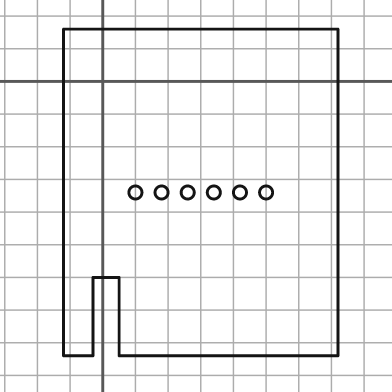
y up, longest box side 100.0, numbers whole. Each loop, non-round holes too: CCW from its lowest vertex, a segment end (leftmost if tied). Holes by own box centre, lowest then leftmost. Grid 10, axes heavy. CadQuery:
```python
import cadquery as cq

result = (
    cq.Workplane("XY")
    .moveTo(-12.0, -84.0)
    .lineTo(-3.0, -84.0)
    .lineTo(-3.0, -60.0)
    .lineTo(5.0, -60.0)
    .lineTo(5.0, -84.0)
    .lineTo(72.0, -84.0)
    .lineTo(72.0, 16.0)
    .lineTo(-12.0, 16.0)
    .close()
    .moveTo(10.0, -34.0)
    .circle(2.0)
    .moveTo(18.0, -34.0)
    .circle(2.0)
    .moveTo(26.0, -34.0)
    .circle(2.0)
    .moveTo(34.0, -34.0)
    .circle(2.0)
    .moveTo(42.0, -34.0)
    .circle(2.0)
    .moveTo(50.0, -34.0)
    .circle(2.0)
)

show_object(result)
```